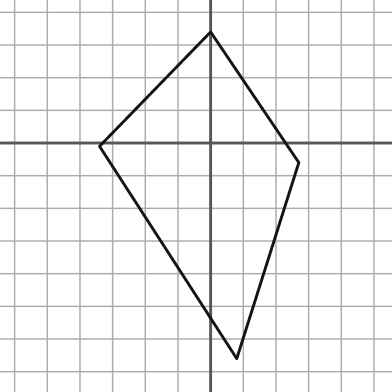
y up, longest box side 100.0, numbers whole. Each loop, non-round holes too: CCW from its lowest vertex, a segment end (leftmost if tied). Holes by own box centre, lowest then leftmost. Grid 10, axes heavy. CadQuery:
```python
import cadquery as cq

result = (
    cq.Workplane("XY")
    .moveTo(8.0, -66.0)
    .lineTo(27.0, -6.0)
    .lineTo(0.0, 34.0)
    .lineTo(-34.0, -1.0)
    .close()
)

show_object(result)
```